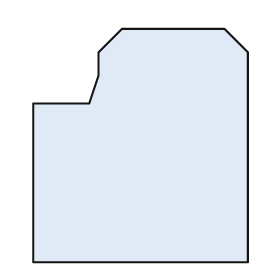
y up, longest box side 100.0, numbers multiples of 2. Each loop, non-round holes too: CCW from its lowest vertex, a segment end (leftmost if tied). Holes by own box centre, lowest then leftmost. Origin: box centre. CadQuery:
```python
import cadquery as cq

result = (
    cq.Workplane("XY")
    .moveTo(-46.0, -50.0)
    .lineTo(46.0, -50.0)
    .lineTo(46.0, 40.0)
    .lineTo(36.0, 50.0)
    .lineTo(-8.0, 50.0)
    .lineTo(-18.0, 40.0)
    .lineTo(-18.0, 30.0)
    .lineTo(-22.0, 18.0)
    .lineTo(-46.0, 18.0)
    .close()
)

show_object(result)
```